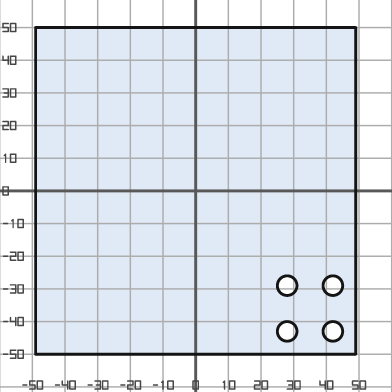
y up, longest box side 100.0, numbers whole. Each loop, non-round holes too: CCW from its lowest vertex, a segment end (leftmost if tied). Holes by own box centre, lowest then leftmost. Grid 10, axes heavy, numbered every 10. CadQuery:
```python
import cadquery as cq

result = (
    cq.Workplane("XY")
    .moveTo(-49.0, -50.0)
    .lineTo(49.0, -50.0)
    .lineTo(49.0, 50.0)
    .lineTo(-49.0, 50.0)
    .close()
    .moveTo(28.0, -43.0)
    .circle(3.0)
    .moveTo(42.0, -43.0)
    .circle(3.0)
    .moveTo(28.0, -29.0)
    .circle(3.0)
    .moveTo(42.0, -29.0)
    .circle(3.0)
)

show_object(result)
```